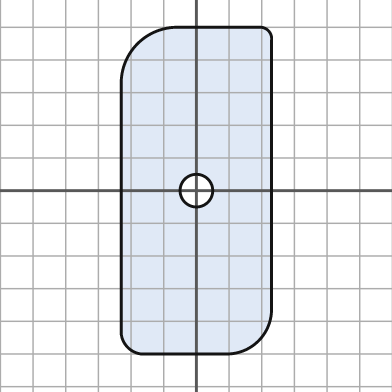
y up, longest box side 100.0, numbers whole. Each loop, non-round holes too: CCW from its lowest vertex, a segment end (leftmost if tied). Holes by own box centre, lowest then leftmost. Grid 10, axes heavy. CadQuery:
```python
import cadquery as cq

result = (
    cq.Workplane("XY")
    .moveTo(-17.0, -50.0)
    .lineTo(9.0, -50.0)
    .threePointArc((19.0, -46.0), (23.0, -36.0))
    .lineTo(23.0, 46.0)
    .threePointArc((22.0, 49.0), (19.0, 50.0))
    .lineTo(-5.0, 50.0)
    .threePointArc((-18.0, 45.0), (-23.0, 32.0))
    .lineTo(-23.0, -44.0)
    .threePointArc((-21.0, -48.0), (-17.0, -50.0))
    .close()
    .moveTo(0.0, 0.0)
    .circle(5.0)
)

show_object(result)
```